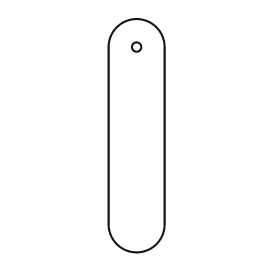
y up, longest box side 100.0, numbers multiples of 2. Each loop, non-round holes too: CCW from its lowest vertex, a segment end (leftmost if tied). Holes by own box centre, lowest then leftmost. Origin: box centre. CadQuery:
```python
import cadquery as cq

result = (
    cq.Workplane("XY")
    .moveTo(-12.0, -38.0)
    .threePointArc((0.0, -50.0), (12.0, -38.0))
    .lineTo(12.0, 38.0)
    .threePointArc((0.0, 50.0), (-12.0, 38.0))
    .close()
    .moveTo(0.0, 38.0)
    .circle(2.0)
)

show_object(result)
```